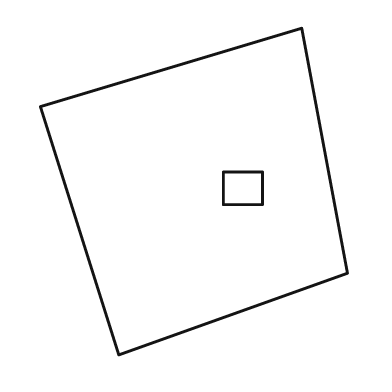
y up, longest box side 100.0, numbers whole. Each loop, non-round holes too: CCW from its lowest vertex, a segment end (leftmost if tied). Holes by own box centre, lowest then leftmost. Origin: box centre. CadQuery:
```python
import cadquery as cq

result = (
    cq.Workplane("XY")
    .moveTo(-23.0, -50.0)
    .lineTo(47.0, -25.0)
    .lineTo(33.0, 50.0)
    .lineTo(-47.0, 26.0)
    .close()
    .moveTo(9.0, -4.0)
    .lineTo(21.0, -4.0)
    .lineTo(21.0, 6.0)
    .lineTo(9.0, 6.0)
    .close()
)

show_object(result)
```